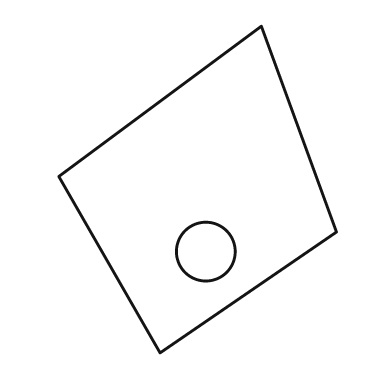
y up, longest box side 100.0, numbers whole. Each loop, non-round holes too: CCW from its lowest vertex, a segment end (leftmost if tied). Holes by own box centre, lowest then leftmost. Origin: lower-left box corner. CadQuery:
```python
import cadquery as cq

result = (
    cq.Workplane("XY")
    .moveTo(31.0, 0.0)
    .lineTo(85.0, 37.0)
    .lineTo(62.0, 100.0)
    .lineTo(0.0, 54.0)
    .close()
    .moveTo(45.0, 31.0)
    .circle(9.0)
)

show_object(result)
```